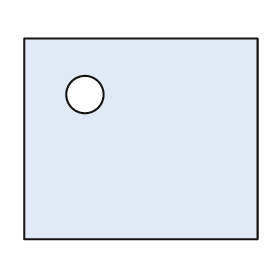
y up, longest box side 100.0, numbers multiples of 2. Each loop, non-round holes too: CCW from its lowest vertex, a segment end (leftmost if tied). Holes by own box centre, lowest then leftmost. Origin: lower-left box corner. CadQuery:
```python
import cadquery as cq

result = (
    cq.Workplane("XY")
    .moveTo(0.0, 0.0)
    .lineTo(100.0, 0.0)
    .lineTo(100.0, 86.0)
    .lineTo(0.0, 86.0)
    .close()
    .moveTo(26.0, 62.0)
    .circle(8.0)
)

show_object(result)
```